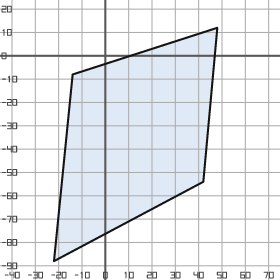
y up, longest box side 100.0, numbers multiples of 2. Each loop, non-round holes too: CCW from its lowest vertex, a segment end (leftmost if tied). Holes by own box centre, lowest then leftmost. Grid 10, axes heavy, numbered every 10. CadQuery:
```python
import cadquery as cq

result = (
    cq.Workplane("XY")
    .moveTo(-22.0, -88.0)
    .lineTo(42.0, -54.0)
    .lineTo(48.0, 12.0)
    .lineTo(-14.0, -8.0)
    .close()
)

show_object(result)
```